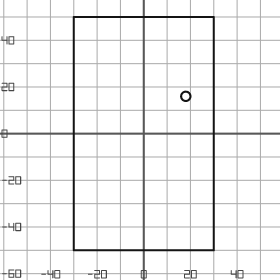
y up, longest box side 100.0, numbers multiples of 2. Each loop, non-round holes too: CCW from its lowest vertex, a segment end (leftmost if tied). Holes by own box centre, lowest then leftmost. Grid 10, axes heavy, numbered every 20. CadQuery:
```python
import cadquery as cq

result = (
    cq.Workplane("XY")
    .moveTo(-30.0, -50.0)
    .lineTo(30.0, -50.0)
    .lineTo(30.0, 50.0)
    .lineTo(-30.0, 50.0)
    .close()
    .moveTo(18.0, 16.0)
    .circle(2.0)
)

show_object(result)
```